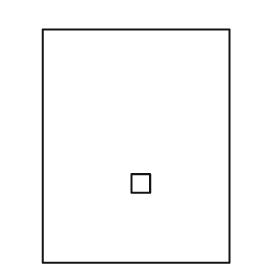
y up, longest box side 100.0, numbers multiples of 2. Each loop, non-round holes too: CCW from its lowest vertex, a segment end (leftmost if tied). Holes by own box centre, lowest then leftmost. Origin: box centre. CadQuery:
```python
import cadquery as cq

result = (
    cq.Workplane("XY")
    .moveTo(-40.0, -50.0)
    .lineTo(40.0, -50.0)
    .lineTo(40.0, 50.0)
    .lineTo(-40.0, 50.0)
    .close()
    .moveTo(-2.0, -20.0)
    .lineTo(6.0, -20.0)
    .lineTo(6.0, -12.0)
    .lineTo(-2.0, -12.0)
    .close()
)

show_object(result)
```